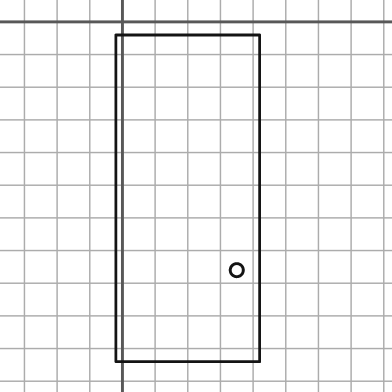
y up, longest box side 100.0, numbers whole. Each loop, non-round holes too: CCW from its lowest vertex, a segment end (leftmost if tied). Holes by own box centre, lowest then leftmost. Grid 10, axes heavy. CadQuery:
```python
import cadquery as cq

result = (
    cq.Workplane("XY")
    .moveTo(-2.0, -104.0)
    .lineTo(42.0, -104.0)
    .lineTo(42.0, -4.0)
    .lineTo(-2.0, -4.0)
    .close()
    .moveTo(35.0, -76.0)
    .circle(2.0)
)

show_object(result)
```